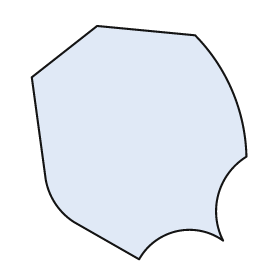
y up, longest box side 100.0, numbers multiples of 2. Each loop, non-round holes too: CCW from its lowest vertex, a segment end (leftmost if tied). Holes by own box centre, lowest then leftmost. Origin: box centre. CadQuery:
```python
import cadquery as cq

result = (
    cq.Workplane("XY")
    .moveTo(0.0, -50.0)
    .threePointArc((16.0, -38.0), (36.0, -42.0))
    .threePointArc((34.0, -22.0), (46.0, -6.0))
    .threePointArc((40.0, 22.0), (24.0, 46.0))
    .lineTo(-18.0, 50.0)
    .lineTo(-46.0, 28.0)
    .lineTo(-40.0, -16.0)
    .threePointArc((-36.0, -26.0), (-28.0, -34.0))
    .close()
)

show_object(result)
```